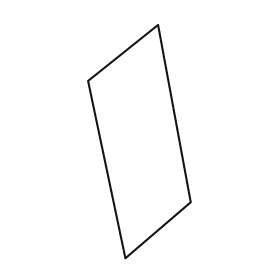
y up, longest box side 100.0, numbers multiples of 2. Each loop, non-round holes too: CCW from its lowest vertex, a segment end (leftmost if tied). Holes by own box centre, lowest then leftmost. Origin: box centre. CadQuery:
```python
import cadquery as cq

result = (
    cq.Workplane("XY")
    .moveTo(-6.0, -50.0)
    .lineTo(22.0, -26.0)
    .lineTo(8.0, 50.0)
    .lineTo(-22.0, 26.0)
    .close()
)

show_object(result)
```